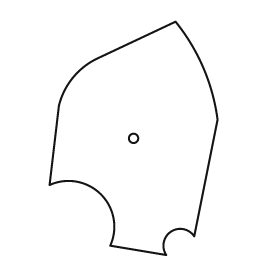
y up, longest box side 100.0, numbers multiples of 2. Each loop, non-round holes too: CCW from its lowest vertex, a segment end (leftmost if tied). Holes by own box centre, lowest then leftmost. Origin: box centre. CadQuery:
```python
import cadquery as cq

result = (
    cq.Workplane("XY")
    .moveTo(14.0, -50.0)
    .threePointArc((16.0, -40.0), (26.0, -42.0))
    .lineTo(36.0, 8.0)
    .threePointArc((30.0, 30.0), (18.0, 50.0))
    .lineTo(-16.0, 34.0)
    .threePointArc((-26.0, 26.0), (-32.0, 14.0))
    .lineTo(-36.0, -20.0)
    .threePointArc((-14.0, -24.0), (-10.0, -46.0))
    .close()
    .moveTo(0.0, 0.0)
    .circle(2.0)
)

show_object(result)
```